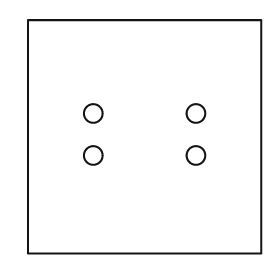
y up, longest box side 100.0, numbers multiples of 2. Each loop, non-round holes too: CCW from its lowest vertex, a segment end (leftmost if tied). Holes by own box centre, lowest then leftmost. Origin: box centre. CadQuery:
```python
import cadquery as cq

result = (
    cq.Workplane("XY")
    .moveTo(-50.0, -50.0)
    .lineTo(50.0, -50.0)
    .lineTo(50.0, 50.0)
    .lineTo(-50.0, 50.0)
    .close()
    .moveTo(-22.0, -8.0)
    .circle(4.0)
    .moveTo(22.0, -8.0)
    .circle(4.0)
    .moveTo(-22.0, 10.0)
    .circle(4.0)
    .moveTo(22.0, 10.0)
    .circle(4.0)
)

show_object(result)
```